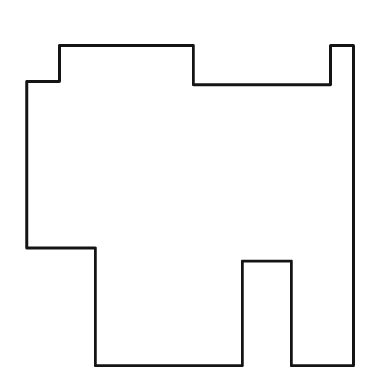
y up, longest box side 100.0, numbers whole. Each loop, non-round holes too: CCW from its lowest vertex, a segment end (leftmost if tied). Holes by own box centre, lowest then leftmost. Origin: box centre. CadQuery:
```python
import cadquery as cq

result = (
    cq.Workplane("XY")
    .moveTo(-29.0, -49.0)
    .lineTo(16.0, -49.0)
    .lineTo(16.0, -17.0)
    .lineTo(31.0, -17.0)
    .lineTo(31.0, -49.0)
    .lineTo(50.0, -49.0)
    .lineTo(50.0, 49.0)
    .lineTo(43.0, 49.0)
    .lineTo(43.0, 37.0)
    .lineTo(1.0, 37.0)
    .lineTo(1.0, 49.0)
    .lineTo(-40.0, 49.0)
    .lineTo(-40.0, 38.0)
    .lineTo(-50.0, 38.0)
    .lineTo(-50.0, -13.0)
    .lineTo(-29.0, -13.0)
    .close()
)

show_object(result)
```